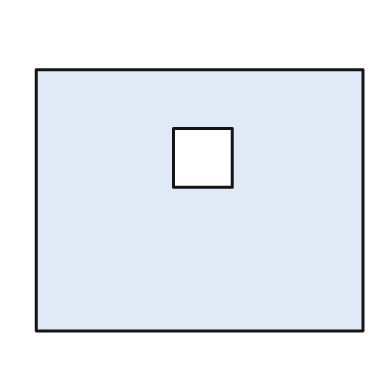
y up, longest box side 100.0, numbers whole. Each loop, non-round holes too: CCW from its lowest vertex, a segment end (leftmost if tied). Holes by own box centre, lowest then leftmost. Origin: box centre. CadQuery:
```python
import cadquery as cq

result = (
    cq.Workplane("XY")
    .moveTo(-50.0, -40.0)
    .lineTo(50.0, -40.0)
    .lineTo(50.0, 40.0)
    .lineTo(-50.0, 40.0)
    .close()
    .moveTo(-8.0, 4.0)
    .lineTo(10.0, 4.0)
    .lineTo(10.0, 22.0)
    .lineTo(-8.0, 22.0)
    .close()
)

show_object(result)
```